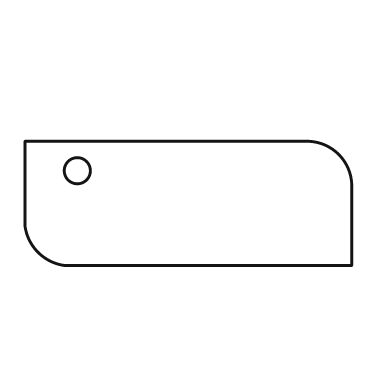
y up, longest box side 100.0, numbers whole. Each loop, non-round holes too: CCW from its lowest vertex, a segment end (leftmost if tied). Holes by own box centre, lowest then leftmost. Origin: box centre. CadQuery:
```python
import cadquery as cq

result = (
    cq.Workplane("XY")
    .moveTo(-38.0, -19.0)
    .lineTo(50.0, -19.0)
    .lineTo(50.0, 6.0)
    .threePointArc((46.0, 15.0), (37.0, 19.0))
    .lineTo(-50.0, 19.0)
    .lineTo(-50.0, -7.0)
    .threePointArc((-46.0, -15.0), (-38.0, -19.0))
    .close()
    .moveTo(-34.0, 10.0)
    .circle(4.0)
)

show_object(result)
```